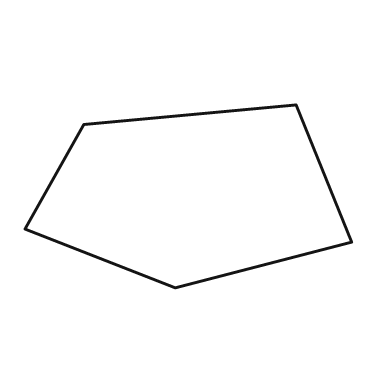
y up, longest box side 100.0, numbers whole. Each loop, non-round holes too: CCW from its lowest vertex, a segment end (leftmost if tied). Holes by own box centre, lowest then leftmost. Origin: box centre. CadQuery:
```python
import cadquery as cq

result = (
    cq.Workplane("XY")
    .moveTo(-4.0, -28.0)
    .lineTo(50.0, -14.0)
    .lineTo(33.0, 28.0)
    .lineTo(-32.0, 22.0)
    .lineTo(-50.0, -10.0)
    .close()
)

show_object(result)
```